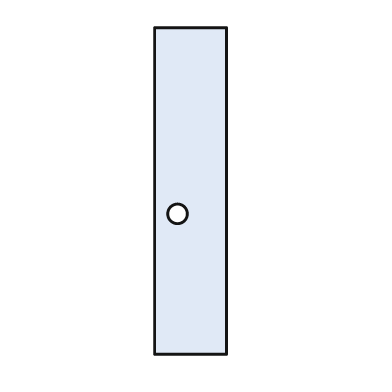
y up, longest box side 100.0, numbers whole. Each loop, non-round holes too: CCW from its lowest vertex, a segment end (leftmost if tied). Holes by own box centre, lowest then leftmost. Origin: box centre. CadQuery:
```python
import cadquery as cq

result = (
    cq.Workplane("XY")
    .moveTo(-11.0, -50.0)
    .lineTo(11.0, -50.0)
    .lineTo(11.0, 50.0)
    .lineTo(-11.0, 50.0)
    .close()
    .moveTo(-4.0, -7.0)
    .circle(3.0)
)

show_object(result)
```